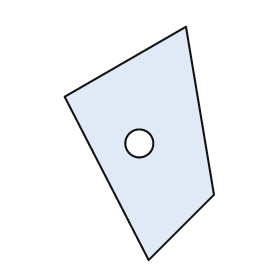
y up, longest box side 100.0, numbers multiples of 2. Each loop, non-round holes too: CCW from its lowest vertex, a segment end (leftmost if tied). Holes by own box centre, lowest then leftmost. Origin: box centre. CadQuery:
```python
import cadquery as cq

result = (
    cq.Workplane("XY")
    .moveTo(4.0, -50.0)
    .lineTo(32.0, -22.0)
    .lineTo(20.0, 50.0)
    .lineTo(-32.0, 20.0)
    .close()
    .moveTo(0.0, 0.0)
    .circle(6.0)
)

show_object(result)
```